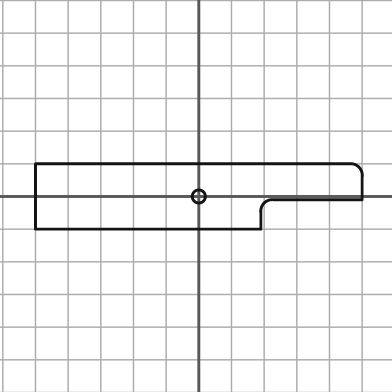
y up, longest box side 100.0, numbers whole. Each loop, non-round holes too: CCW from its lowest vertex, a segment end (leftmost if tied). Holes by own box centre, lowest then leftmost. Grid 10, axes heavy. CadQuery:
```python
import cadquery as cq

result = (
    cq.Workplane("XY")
    .moveTo(-50.0, -10.0)
    .lineTo(19.0, -10.0)
    .lineTo(19.0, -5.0)
    .threePointArc((20.0, -2.0), (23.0, -1.0))
    .lineTo(50.0, -1.0)
    .lineTo(50.0, 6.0)
    .threePointArc((49.0, 9.0), (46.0, 10.0))
    .lineTo(-50.0, 10.0)
    .close()
    .moveTo(0.0, 0.0)
    .circle(2.0)
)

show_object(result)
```